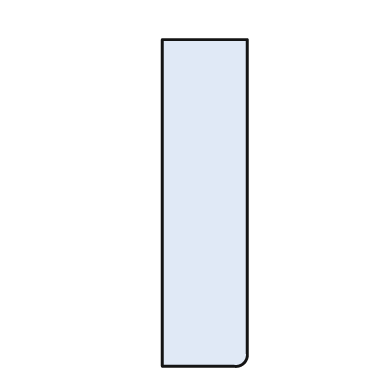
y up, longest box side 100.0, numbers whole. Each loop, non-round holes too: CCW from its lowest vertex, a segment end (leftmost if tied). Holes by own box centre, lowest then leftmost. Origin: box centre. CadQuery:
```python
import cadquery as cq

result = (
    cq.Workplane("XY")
    .moveTo(-13.0, -50.0)
    .lineTo(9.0, -50.0)
    .threePointArc((12.0, -49.0), (13.0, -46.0))
    .lineTo(13.0, 50.0)
    .lineTo(-13.0, 50.0)
    .close()
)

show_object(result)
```